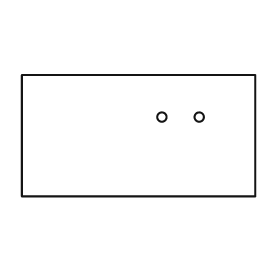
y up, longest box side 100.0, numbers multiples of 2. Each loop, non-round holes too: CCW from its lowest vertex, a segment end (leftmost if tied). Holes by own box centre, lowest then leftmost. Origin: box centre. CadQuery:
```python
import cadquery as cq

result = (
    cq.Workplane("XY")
    .moveTo(-50.0, -26.0)
    .lineTo(50.0, -26.0)
    .lineTo(50.0, 26.0)
    .lineTo(-50.0, 26.0)
    .close()
    .moveTo(10.0, 8.0)
    .circle(2.0)
    .moveTo(26.0, 8.0)
    .circle(2.0)
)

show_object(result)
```